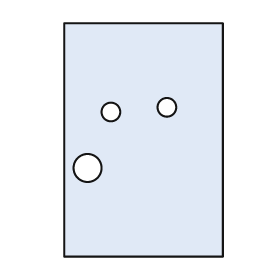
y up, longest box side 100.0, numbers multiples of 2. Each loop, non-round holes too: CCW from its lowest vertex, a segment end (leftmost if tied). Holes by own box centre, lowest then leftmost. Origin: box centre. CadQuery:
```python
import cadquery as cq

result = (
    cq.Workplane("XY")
    .moveTo(-34.0, -50.0)
    .lineTo(34.0, -50.0)
    .lineTo(34.0, 50.0)
    .lineTo(-34.0, 50.0)
    .close()
    .moveTo(-24.0, -12.0)
    .circle(6.0)
    .moveTo(-14.0, 12.0)
    .circle(4.0)
    .moveTo(10.0, 14.0)
    .circle(4.0)
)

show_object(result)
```